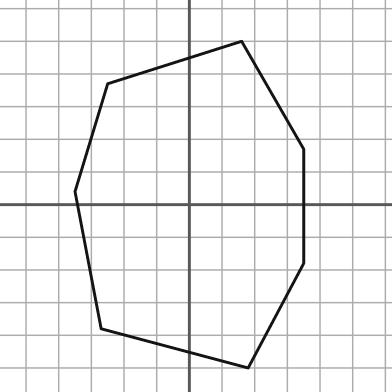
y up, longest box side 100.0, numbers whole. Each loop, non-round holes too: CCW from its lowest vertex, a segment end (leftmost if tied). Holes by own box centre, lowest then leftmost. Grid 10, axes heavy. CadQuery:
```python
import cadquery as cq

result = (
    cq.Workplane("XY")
    .moveTo(18.0, -50.0)
    .lineTo(35.0, -18.0)
    .lineTo(35.0, 17.0)
    .lineTo(16.0, 50.0)
    .lineTo(-25.0, 37.0)
    .lineTo(-35.0, 4.0)
    .lineTo(-27.0, -38.0)
    .close()
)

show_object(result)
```